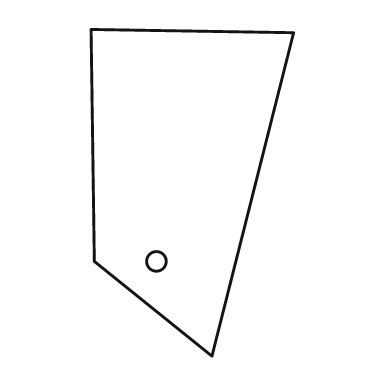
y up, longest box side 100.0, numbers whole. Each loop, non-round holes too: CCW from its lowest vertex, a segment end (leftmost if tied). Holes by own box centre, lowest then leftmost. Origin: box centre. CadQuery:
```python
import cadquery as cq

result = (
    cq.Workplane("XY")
    .moveTo(6.0, -50.0)
    .lineTo(31.0, 49.0)
    .lineTo(-31.0, 50.0)
    .lineTo(-30.0, -21.0)
    .close()
    .moveTo(-11.0, -21.0)
    .circle(3.0)
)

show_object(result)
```